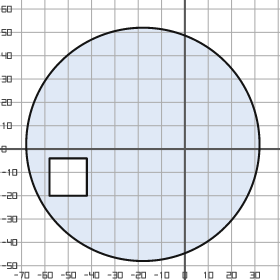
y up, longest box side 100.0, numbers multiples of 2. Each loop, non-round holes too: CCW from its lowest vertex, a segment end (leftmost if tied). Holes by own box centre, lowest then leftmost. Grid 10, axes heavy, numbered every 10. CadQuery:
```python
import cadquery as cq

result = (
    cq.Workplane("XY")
    .moveTo(-18.0, 2.0)
    .circle(50.0)
    .moveTo(-58.0, -20.0)
    .lineTo(-42.0, -20.0)
    .lineTo(-42.0, -4.0)
    .lineTo(-58.0, -4.0)
    .close()
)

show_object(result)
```